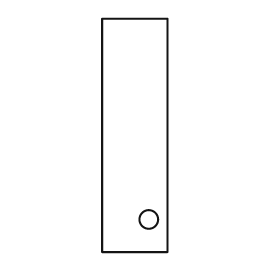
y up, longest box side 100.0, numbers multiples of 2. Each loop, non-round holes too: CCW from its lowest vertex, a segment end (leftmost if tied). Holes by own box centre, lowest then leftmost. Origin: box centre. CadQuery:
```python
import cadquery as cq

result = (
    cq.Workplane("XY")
    .moveTo(-14.0, -50.0)
    .lineTo(14.0, -50.0)
    .lineTo(14.0, 50.0)
    .lineTo(-14.0, 50.0)
    .close()
    .moveTo(6.0, -36.0)
    .circle(4.0)
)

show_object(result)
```